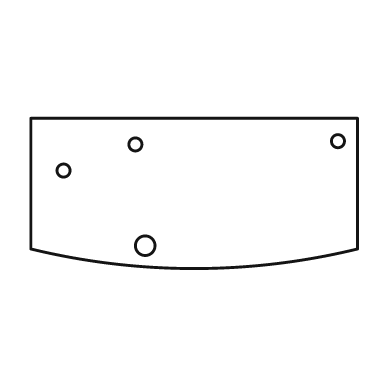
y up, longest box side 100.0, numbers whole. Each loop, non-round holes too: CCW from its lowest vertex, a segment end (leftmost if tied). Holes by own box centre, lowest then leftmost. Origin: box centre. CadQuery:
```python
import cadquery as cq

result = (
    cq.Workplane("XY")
    .moveTo(-50.0, -17.0)
    .threePointArc((0.0, -23.0), (50.0, -17.0))
    .lineTo(50.0, 23.0)
    .lineTo(-50.0, 23.0)
    .close()
    .moveTo(-15.0, -16.0)
    .circle(3.0)
    .moveTo(-40.0, 7.0)
    .circle(2.0)
    .moveTo(-18.0, 15.0)
    .circle(2.0)
    .moveTo(44.0, 16.0)
    .circle(2.0)
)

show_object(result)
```